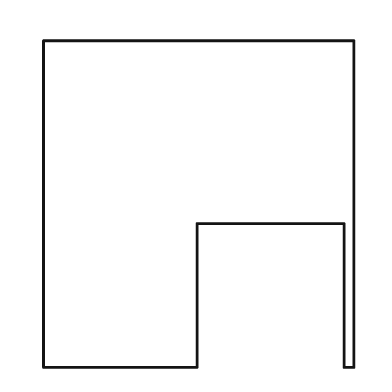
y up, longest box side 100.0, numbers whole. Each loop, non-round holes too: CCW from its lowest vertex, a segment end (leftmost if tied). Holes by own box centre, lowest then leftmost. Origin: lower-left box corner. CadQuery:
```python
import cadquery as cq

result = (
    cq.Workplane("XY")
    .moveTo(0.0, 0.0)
    .lineTo(47.0, 0.0)
    .lineTo(47.0, 44.0)
    .lineTo(92.0, 44.0)
    .lineTo(92.0, 0.0)
    .lineTo(95.0, 0.0)
    .lineTo(95.0, 100.0)
    .lineTo(0.0, 100.0)
    .close()
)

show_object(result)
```